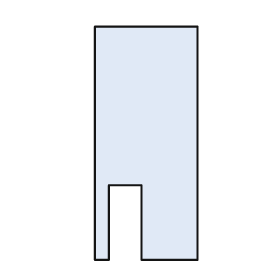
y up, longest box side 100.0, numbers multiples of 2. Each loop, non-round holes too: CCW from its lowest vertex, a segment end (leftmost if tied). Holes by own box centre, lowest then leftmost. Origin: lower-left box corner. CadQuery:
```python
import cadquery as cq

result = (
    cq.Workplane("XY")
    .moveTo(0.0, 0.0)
    .lineTo(6.0, 0.0)
    .lineTo(6.0, 32.0)
    .lineTo(20.0, 32.0)
    .lineTo(20.0, 0.0)
    .lineTo(44.0, 0.0)
    .lineTo(44.0, 100.0)
    .lineTo(0.0, 100.0)
    .close()
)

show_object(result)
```